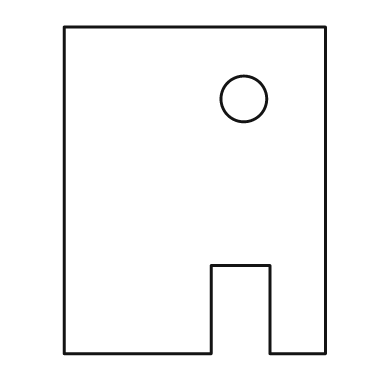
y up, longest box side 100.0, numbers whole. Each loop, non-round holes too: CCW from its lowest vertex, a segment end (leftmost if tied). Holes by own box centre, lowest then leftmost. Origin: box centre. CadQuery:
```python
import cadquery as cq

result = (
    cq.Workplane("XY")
    .moveTo(-40.0, -50.0)
    .lineTo(5.0, -50.0)
    .lineTo(5.0, -23.0)
    .lineTo(23.0, -23.0)
    .lineTo(23.0, -50.0)
    .lineTo(40.0, -50.0)
    .lineTo(40.0, 50.0)
    .lineTo(-40.0, 50.0)
    .close()
    .moveTo(15.0, 28.0)
    .circle(7.0)
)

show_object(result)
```